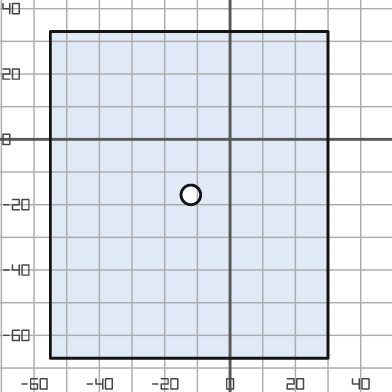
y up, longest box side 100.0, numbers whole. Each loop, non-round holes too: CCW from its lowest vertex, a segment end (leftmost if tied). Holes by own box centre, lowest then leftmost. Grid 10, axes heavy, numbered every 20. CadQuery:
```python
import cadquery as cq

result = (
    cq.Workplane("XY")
    .moveTo(-55.0, -67.0)
    .lineTo(30.0, -67.0)
    .lineTo(30.0, 33.0)
    .lineTo(-55.0, 33.0)
    .close()
    .moveTo(-12.0, -17.0)
    .circle(3.0)
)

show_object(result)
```